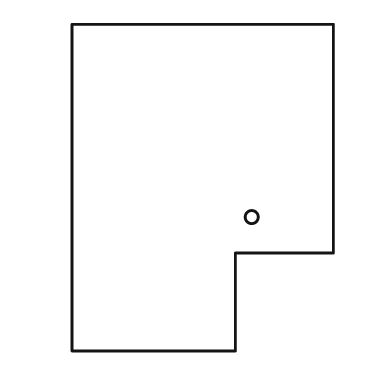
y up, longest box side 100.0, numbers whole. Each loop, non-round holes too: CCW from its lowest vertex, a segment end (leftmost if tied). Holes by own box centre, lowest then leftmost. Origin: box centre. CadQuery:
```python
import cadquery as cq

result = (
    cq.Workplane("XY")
    .moveTo(-40.0, -50.0)
    .lineTo(10.0, -50.0)
    .lineTo(10.0, -20.0)
    .lineTo(40.0, -20.0)
    .lineTo(40.0, 50.0)
    .lineTo(-40.0, 50.0)
    .close()
    .moveTo(15.0, -9.0)
    .circle(2.0)
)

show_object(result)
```